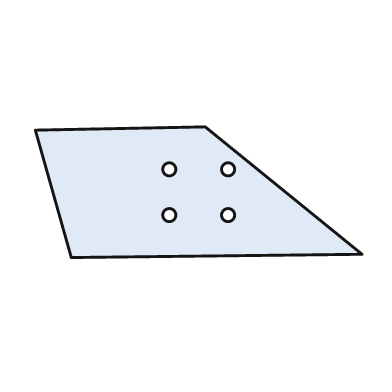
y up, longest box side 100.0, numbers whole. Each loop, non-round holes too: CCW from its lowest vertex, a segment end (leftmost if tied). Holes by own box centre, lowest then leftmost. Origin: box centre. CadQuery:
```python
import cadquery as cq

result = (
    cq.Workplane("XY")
    .moveTo(-39.0, -20.0)
    .lineTo(50.0, -19.0)
    .lineTo(2.0, 20.0)
    .lineTo(-50.0, 19.0)
    .close()
    .moveTo(-9.0, -7.0)
    .circle(2.0)
    .moveTo(9.0, -7.0)
    .circle(2.0)
    .moveTo(-9.0, 7.0)
    .circle(2.0)
    .moveTo(9.0, 7.0)
    .circle(2.0)
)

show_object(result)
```